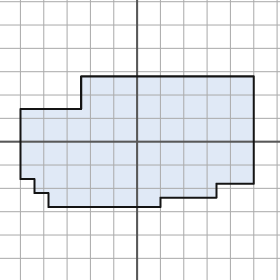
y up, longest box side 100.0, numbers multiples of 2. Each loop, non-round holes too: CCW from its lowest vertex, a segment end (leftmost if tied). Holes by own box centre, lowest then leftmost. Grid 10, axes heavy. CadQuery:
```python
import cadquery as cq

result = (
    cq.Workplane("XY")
    .moveTo(-38.0, -28.0)
    .lineTo(10.0, -28.0)
    .lineTo(10.0, -24.0)
    .lineTo(34.0, -24.0)
    .lineTo(34.0, -18.0)
    .lineTo(50.0, -18.0)
    .lineTo(50.0, 28.0)
    .lineTo(-24.0, 28.0)
    .lineTo(-24.0, 14.0)
    .lineTo(-50.0, 14.0)
    .lineTo(-50.0, -16.0)
    .lineTo(-44.0, -16.0)
    .lineTo(-44.0, -22.0)
    .lineTo(-38.0, -22.0)
    .close()
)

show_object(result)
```